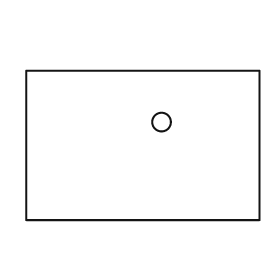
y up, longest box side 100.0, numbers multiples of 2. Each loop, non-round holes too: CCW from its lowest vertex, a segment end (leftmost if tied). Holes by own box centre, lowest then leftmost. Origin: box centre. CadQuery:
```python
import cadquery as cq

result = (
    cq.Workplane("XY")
    .moveTo(-50.0, -32.0)
    .lineTo(50.0, -32.0)
    .lineTo(50.0, 32.0)
    .lineTo(-50.0, 32.0)
    .close()
    .moveTo(8.0, 10.0)
    .circle(4.0)
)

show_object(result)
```